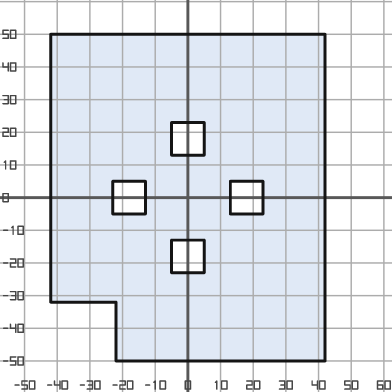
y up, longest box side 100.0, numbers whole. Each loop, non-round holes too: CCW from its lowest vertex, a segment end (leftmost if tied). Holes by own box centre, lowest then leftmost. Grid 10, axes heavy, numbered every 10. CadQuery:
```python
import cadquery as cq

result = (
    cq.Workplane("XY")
    .moveTo(-22.0, -50.0)
    .lineTo(42.0, -50.0)
    .lineTo(42.0, 50.0)
    .lineTo(-42.0, 50.0)
    .lineTo(-42.0, -32.0)
    .lineTo(-22.0, -32.0)
    .close()
    .moveTo(-5.0, -23.0)
    .lineTo(5.0, -23.0)
    .lineTo(5.0, -13.0)
    .lineTo(-5.0, -13.0)
    .close()
    .moveTo(-23.0, -5.0)
    .lineTo(-13.0, -5.0)
    .lineTo(-13.0, 5.0)
    .lineTo(-23.0, 5.0)
    .close()
    .moveTo(13.0, -5.0)
    .lineTo(23.0, -5.0)
    .lineTo(23.0, 5.0)
    .lineTo(13.0, 5.0)
    .close()
    .moveTo(-5.0, 13.0)
    .lineTo(5.0, 13.0)
    .lineTo(5.0, 23.0)
    .lineTo(-5.0, 23.0)
    .close()
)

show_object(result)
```